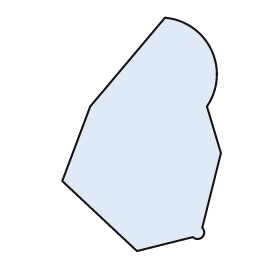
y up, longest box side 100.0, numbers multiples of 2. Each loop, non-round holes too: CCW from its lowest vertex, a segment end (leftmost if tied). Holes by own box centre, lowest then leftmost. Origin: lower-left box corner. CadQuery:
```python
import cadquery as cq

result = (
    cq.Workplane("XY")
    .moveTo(32.0, 0.0)
    .lineTo(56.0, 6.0)
    .threePointArc((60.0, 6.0), (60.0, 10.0))
    .lineTo(68.0, 42.0)
    .lineTo(62.0, 62.0)
    .threePointArc((64.0, 86.0), (44.0, 100.0))
    .lineTo(12.0, 62.0)
    .lineTo(0.0, 30.0)
    .close()
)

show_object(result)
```